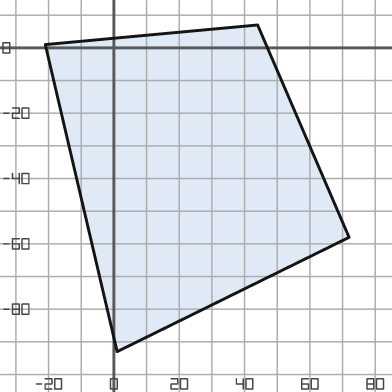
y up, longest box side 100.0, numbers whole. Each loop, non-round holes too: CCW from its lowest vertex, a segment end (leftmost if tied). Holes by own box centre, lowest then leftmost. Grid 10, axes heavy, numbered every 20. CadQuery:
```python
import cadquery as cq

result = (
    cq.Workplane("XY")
    .moveTo(1.0, -93.0)
    .lineTo(72.0, -58.0)
    .lineTo(44.0, 7.0)
    .lineTo(-21.0, 1.0)
    .close()
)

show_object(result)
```